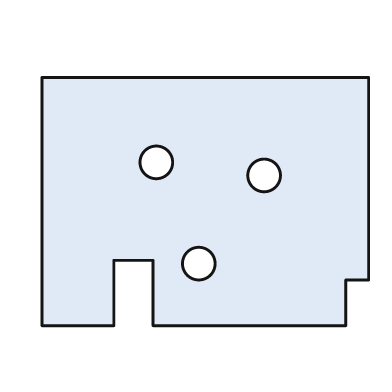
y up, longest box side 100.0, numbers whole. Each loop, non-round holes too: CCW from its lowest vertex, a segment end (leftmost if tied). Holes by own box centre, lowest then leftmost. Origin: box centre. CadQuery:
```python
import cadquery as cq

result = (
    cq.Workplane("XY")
    .moveTo(-50.0, -38.0)
    .lineTo(-28.0, -38.0)
    .lineTo(-28.0, -18.0)
    .lineTo(-16.0, -18.0)
    .lineTo(-16.0, -38.0)
    .lineTo(43.0, -38.0)
    .lineTo(43.0, -24.0)
    .lineTo(50.0, -24.0)
    .lineTo(50.0, 38.0)
    .lineTo(-50.0, 38.0)
    .close()
    .moveTo(-2.0, -19.0)
    .circle(5.0)
    .moveTo(18.0, 8.0)
    .circle(5.0)
    .moveTo(-15.0, 12.0)
    .circle(5.0)
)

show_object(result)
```